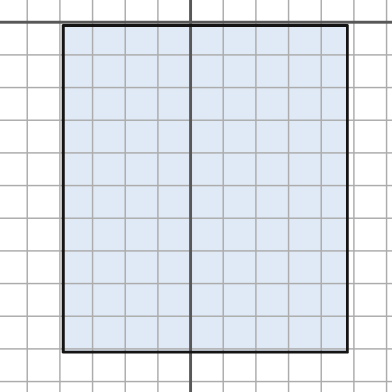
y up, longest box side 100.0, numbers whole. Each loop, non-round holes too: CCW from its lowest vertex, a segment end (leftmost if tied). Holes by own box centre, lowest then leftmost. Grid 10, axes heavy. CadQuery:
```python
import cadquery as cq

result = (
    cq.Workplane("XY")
    .moveTo(-39.0, -101.0)
    .lineTo(48.0, -101.0)
    .lineTo(48.0, -1.0)
    .lineTo(-39.0, -1.0)
    .close()
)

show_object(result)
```